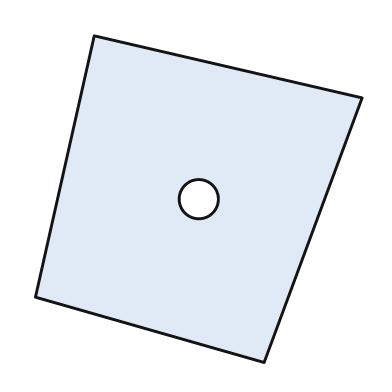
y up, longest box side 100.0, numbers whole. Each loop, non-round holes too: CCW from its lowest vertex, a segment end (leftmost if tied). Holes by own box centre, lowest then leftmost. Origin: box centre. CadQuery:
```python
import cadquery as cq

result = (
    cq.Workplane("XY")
    .moveTo(20.0, -50.0)
    .lineTo(50.0, 31.0)
    .lineTo(-32.0, 50.0)
    .lineTo(-50.0, -30.0)
    .close()
    .moveTo(0.0, 0.0)
    .circle(6.0)
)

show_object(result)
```